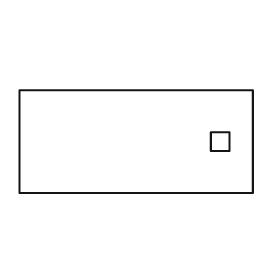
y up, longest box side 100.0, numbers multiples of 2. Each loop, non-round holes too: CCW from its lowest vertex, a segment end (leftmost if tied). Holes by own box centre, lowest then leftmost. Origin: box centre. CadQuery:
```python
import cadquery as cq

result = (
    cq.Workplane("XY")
    .moveTo(-50.0, -22.0)
    .lineTo(50.0, -22.0)
    .lineTo(50.0, 22.0)
    .lineTo(-50.0, 22.0)
    .close()
    .moveTo(32.0, -4.0)
    .lineTo(40.0, -4.0)
    .lineTo(40.0, 4.0)
    .lineTo(32.0, 4.0)
    .close()
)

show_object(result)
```